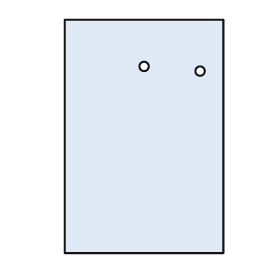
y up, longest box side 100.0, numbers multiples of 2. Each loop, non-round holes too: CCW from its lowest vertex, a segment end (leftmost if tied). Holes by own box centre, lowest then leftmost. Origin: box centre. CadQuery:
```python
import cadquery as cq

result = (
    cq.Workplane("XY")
    .moveTo(-34.0, -50.0)
    .lineTo(34.0, -50.0)
    .lineTo(34.0, 50.0)
    .lineTo(-34.0, 50.0)
    .close()
    .moveTo(24.0, 28.0)
    .circle(2.0)
    .moveTo(0.0, 30.0)
    .circle(2.0)
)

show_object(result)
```